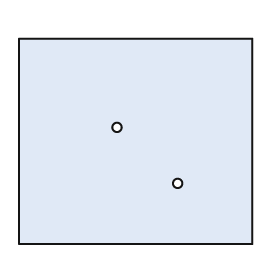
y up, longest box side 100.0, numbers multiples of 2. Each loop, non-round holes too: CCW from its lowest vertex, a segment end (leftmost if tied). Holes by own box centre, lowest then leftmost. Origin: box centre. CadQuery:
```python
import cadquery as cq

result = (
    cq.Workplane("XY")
    .moveTo(-50.0, -44.0)
    .lineTo(50.0, -44.0)
    .lineTo(50.0, 44.0)
    .lineTo(-50.0, 44.0)
    .close()
    .moveTo(18.0, -18.0)
    .circle(2.0)
    .moveTo(-8.0, 6.0)
    .circle(2.0)
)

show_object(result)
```